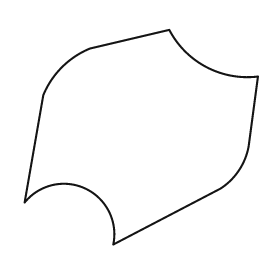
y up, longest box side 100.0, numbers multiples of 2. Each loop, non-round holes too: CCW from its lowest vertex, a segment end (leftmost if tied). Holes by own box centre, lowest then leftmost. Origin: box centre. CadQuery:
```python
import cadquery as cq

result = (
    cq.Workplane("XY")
    .moveTo(-12.0, -46.0)
    .lineTo(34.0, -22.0)
    .threePointArc((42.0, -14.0), (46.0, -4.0))
    .lineTo(50.0, 26.0)
    .threePointArc((28.0, 30.0), (12.0, 46.0))
    .lineTo(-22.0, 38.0)
    .threePointArc((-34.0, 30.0), (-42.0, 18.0))
    .lineTo(-50.0, -28.0)
    .threePointArc((-24.0, -22.0), (-12.0, -46.0))
    .close()
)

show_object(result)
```